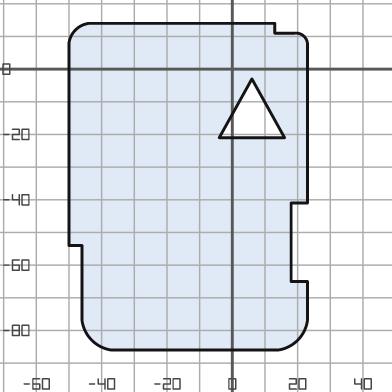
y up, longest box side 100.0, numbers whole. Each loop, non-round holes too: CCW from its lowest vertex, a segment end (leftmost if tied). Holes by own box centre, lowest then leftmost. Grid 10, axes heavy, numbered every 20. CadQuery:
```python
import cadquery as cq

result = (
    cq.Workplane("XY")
    .moveTo(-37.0, -86.0)
    .lineTo(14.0, -86.0)
    .threePointArc((20.0, -83.0), (23.0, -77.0))
    .lineTo(23.0, -65.0)
    .lineTo(18.0, -65.0)
    .lineTo(18.0, -41.0)
    .lineTo(23.0, -41.0)
    .lineTo(23.0, 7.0)
    .threePointArc((22.0, 10.0), (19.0, 11.0))
    .lineTo(13.0, 11.0)
    .lineTo(13.0, 14.0)
    .lineTo(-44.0, 14.0)
    .threePointArc((-48.0, 12.0), (-50.0, 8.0))
    .lineTo(-50.0, -54.0)
    .lineTo(-46.0, -54.0)
    .lineTo(-46.0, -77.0)
    .threePointArc((-43.0, -83.0), (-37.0, -86.0))
    .close()
    .moveTo(-4.0, -21.0)
    .lineTo(16.0, -21.0)
    .lineTo(6.0, -3.0)
    .close()
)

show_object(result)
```